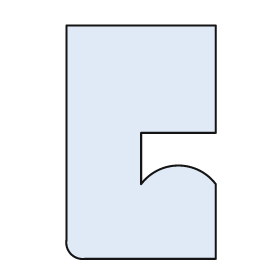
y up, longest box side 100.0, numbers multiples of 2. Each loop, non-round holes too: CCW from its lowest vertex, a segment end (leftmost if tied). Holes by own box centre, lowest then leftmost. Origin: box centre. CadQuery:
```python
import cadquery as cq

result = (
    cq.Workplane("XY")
    .moveTo(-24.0, -50.0)
    .lineTo(32.0, -50.0)
    .lineTo(32.0, -18.0)
    .threePointArc((16.0, -10.0), (0.0, -18.0))
    .lineTo(0.0, 4.0)
    .lineTo(32.0, 4.0)
    .lineTo(32.0, 50.0)
    .lineTo(-32.0, 50.0)
    .lineTo(-32.0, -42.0)
    .threePointArc((-30.0, -48.0), (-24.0, -50.0))
    .close()
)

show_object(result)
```